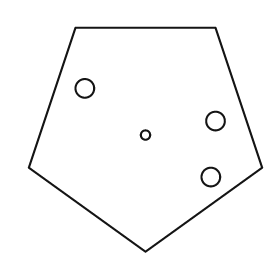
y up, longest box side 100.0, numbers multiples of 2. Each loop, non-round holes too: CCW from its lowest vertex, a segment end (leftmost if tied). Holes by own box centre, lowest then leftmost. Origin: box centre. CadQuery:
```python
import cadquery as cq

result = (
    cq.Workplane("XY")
    .moveTo(0.0, -48.0)
    .lineTo(50.0, -12.0)
    .lineTo(30.0, 48.0)
    .lineTo(-30.0, 48.0)
    .lineTo(-50.0, -12.0)
    .close()
    .moveTo(28.0, -16.0)
    .circle(4.0)
    .moveTo(0.0, 2.0)
    .circle(2.0)
    .moveTo(30.0, 8.0)
    .circle(4.0)
    .moveTo(-26.0, 22.0)
    .circle(4.0)
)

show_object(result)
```